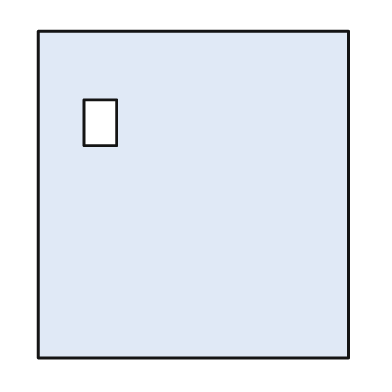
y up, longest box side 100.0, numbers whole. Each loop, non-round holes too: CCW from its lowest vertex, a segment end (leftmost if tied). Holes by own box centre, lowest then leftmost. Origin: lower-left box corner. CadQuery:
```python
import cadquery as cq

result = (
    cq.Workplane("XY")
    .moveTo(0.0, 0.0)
    .lineTo(95.0, 0.0)
    .lineTo(95.0, 100.0)
    .lineTo(0.0, 100.0)
    .close()
    .moveTo(14.0, 65.0)
    .lineTo(24.0, 65.0)
    .lineTo(24.0, 79.0)
    .lineTo(14.0, 79.0)
    .close()
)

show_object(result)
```